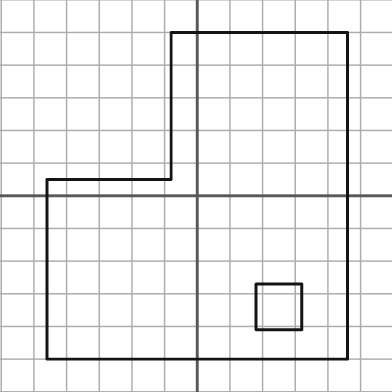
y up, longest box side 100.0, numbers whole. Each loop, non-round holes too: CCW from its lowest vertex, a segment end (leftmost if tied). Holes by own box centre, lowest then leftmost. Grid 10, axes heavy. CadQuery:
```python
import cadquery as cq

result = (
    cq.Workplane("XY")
    .moveTo(-46.0, -50.0)
    .lineTo(46.0, -50.0)
    .lineTo(46.0, 50.0)
    .lineTo(-8.0, 50.0)
    .lineTo(-8.0, 5.0)
    .lineTo(-46.0, 5.0)
    .close()
    .moveTo(18.0, -41.0)
    .lineTo(32.0, -41.0)
    .lineTo(32.0, -27.0)
    .lineTo(18.0, -27.0)
    .close()
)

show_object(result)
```